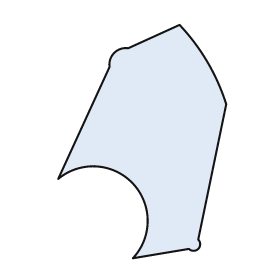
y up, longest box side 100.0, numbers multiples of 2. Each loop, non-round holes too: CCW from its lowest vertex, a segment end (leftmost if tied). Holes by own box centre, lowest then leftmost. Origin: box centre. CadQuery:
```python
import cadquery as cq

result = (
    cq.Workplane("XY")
    .moveTo(-4.0, -50.0)
    .lineTo(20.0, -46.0)
    .threePointArc((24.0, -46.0), (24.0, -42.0))
    .lineTo(36.0, 16.0)
    .threePointArc((28.0, 34.0), (16.0, 50.0))
    .lineTo(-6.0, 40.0)
    .threePointArc((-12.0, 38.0), (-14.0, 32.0))
    .lineTo(-36.0, -16.0)
    .threePointArc((-4.0, -18.0), (-4.0, -50.0))
    .close()
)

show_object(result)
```